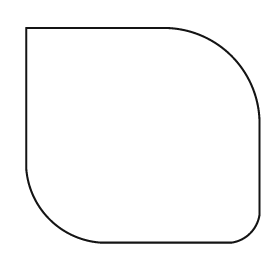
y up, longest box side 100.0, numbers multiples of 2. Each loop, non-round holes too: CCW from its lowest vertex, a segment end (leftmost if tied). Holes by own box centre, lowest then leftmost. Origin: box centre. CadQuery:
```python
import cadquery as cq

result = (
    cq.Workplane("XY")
    .moveTo(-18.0, -46.0)
    .lineTo(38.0, -46.0)
    .threePointArc((46.0, -42.0), (50.0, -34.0))
    .lineTo(50.0, 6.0)
    .threePointArc((38.0, 34.0), (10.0, 46.0))
    .lineTo(-50.0, 46.0)
    .lineTo(-50.0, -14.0)
    .threePointArc((-40.0, -36.0), (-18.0, -46.0))
    .close()
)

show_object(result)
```